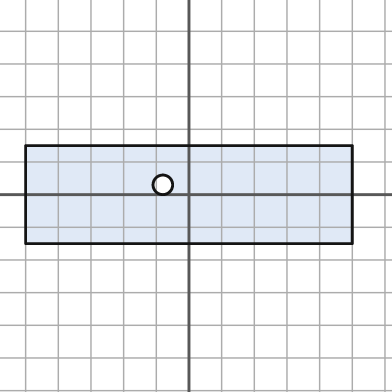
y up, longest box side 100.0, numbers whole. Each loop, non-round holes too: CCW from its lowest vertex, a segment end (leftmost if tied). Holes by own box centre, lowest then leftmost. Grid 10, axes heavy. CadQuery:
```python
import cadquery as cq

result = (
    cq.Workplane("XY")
    .moveTo(-50.0, -15.0)
    .lineTo(50.0, -15.0)
    .lineTo(50.0, 15.0)
    .lineTo(-50.0, 15.0)
    .close()
    .moveTo(-8.0, 3.0)
    .circle(3.0)
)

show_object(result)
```